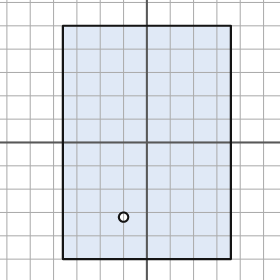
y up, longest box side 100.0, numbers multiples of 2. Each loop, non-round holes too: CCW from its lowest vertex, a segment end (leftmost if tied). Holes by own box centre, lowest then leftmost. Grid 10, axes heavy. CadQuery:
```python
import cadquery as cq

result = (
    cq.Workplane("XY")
    .moveTo(-36.0, -50.0)
    .lineTo(36.0, -50.0)
    .lineTo(36.0, 50.0)
    .lineTo(-36.0, 50.0)
    .close()
    .moveTo(-10.0, -32.0)
    .circle(2.0)
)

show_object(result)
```